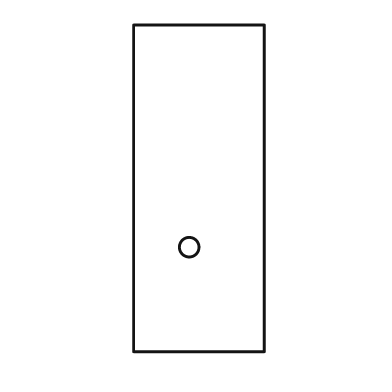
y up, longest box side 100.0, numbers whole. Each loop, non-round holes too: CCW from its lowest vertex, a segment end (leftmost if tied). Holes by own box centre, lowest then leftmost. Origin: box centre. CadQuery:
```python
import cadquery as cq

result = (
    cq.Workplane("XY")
    .moveTo(-20.0, -50.0)
    .lineTo(20.0, -50.0)
    .lineTo(20.0, 50.0)
    .lineTo(-20.0, 50.0)
    .close()
    .moveTo(-3.0, -18.0)
    .circle(3.0)
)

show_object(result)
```